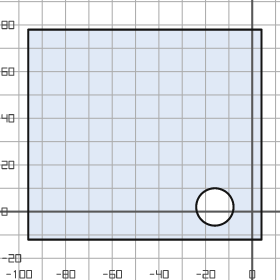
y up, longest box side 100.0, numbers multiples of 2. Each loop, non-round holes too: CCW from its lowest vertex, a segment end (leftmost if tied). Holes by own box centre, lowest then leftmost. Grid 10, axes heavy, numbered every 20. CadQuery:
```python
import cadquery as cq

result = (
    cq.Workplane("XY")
    .moveTo(-96.0, -12.0)
    .lineTo(4.0, -12.0)
    .lineTo(4.0, 78.0)
    .lineTo(-96.0, 78.0)
    .close()
    .moveTo(-16.0, 2.0)
    .circle(8.0)
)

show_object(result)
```